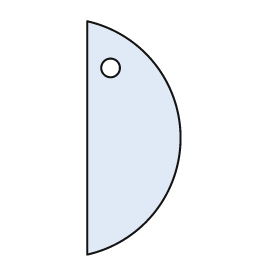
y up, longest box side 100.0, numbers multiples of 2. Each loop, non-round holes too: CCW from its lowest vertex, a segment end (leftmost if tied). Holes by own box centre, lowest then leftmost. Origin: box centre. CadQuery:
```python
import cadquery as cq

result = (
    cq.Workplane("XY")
    .moveTo(-20.0, -50.0)
    .threePointArc((20.0, 0.0), (-20.0, 50.0))
    .close()
    .moveTo(-10.0, 30.0)
    .circle(4.0)
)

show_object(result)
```